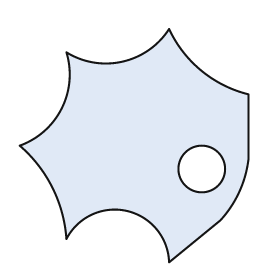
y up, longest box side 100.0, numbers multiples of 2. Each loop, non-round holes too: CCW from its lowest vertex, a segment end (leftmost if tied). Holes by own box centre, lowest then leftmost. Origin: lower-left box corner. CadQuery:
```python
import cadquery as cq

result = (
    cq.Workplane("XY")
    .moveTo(64.0, 0.0)
    .lineTo(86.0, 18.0)
    .threePointArc((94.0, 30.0), (98.0, 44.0))
    .lineTo(98.0, 72.0)
    .threePointArc((78.0, 82.0), (64.0, 100.0))
    .threePointArc((44.0, 86.0), (20.0, 90.0))
    .threePointArc((18.0, 66.0), (0.0, 50.0))
    .threePointArc((14.0, 32.0), (20.0, 10.0))
    .threePointArc((46.0, 22.0), (64.0, 0.0))
    .close()
    .moveTo(78.0, 40.0)
    .circle(10.0)
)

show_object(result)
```